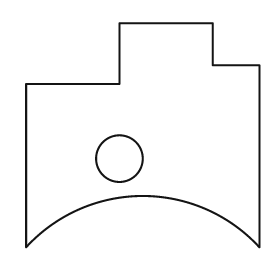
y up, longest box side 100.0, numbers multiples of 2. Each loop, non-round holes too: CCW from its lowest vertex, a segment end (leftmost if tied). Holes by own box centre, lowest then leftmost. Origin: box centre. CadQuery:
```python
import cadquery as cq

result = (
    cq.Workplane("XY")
    .moveTo(-50.0, -48.0)
    .threePointArc((0.0, -26.0), (50.0, -48.0))
    .lineTo(50.0, 30.0)
    .lineTo(30.0, 30.0)
    .lineTo(30.0, 48.0)
    .lineTo(-10.0, 48.0)
    .lineTo(-10.0, 22.0)
    .lineTo(-50.0, 22.0)
    .close()
    .moveTo(-10.0, -10.0)
    .circle(10.0)
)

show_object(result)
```